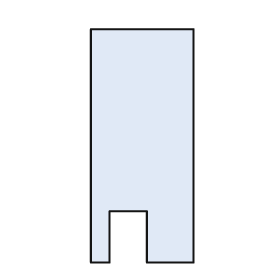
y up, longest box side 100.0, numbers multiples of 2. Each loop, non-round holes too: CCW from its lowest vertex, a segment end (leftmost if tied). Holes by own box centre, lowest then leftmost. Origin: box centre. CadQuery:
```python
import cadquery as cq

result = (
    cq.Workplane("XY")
    .moveTo(-22.0, -50.0)
    .lineTo(-14.0, -50.0)
    .lineTo(-14.0, -28.0)
    .lineTo(2.0, -28.0)
    .lineTo(2.0, -50.0)
    .lineTo(22.0, -50.0)
    .lineTo(22.0, 50.0)
    .lineTo(-22.0, 50.0)
    .close()
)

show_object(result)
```